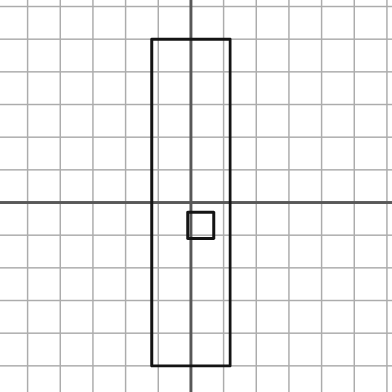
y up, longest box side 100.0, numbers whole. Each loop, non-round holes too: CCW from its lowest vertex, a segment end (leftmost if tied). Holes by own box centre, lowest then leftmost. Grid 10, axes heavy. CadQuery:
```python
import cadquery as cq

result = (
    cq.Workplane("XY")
    .moveTo(-12.0, -50.0)
    .lineTo(12.0, -50.0)
    .lineTo(12.0, 50.0)
    .lineTo(-12.0, 50.0)
    .close()
    .moveTo(-1.0, -11.0)
    .lineTo(7.0, -11.0)
    .lineTo(7.0, -3.0)
    .lineTo(-1.0, -3.0)
    .close()
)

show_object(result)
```